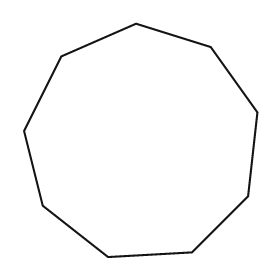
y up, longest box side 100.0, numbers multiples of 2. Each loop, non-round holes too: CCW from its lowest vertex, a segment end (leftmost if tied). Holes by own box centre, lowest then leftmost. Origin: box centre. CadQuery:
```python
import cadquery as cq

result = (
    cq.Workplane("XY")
    .moveTo(-14.0, -50.0)
    .lineTo(22.0, -48.0)
    .lineTo(46.0, -24.0)
    .lineTo(50.0, 12.0)
    .lineTo(30.0, 40.0)
    .lineTo(-2.0, 50.0)
    .lineTo(-34.0, 36.0)
    .lineTo(-50.0, 4.0)
    .lineTo(-42.0, -28.0)
    .close()
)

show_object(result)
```